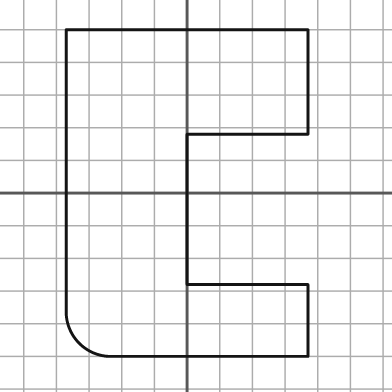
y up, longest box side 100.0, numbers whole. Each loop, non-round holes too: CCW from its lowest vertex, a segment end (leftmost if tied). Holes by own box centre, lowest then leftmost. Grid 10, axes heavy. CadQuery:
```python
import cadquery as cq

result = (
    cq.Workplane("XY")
    .moveTo(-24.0, -50.0)
    .lineTo(37.0, -50.0)
    .lineTo(37.0, -28.0)
    .lineTo(0.0, -28.0)
    .lineTo(0.0, 18.0)
    .lineTo(37.0, 18.0)
    .lineTo(37.0, 50.0)
    .lineTo(-37.0, 50.0)
    .lineTo(-37.0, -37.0)
    .threePointArc((-33.0, -46.0), (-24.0, -50.0))
    .close()
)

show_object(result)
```